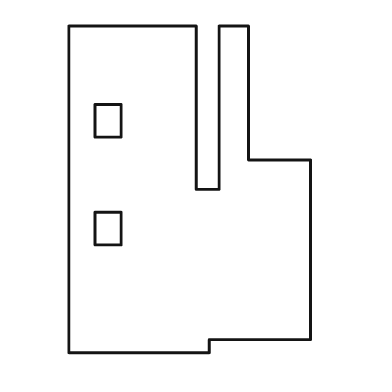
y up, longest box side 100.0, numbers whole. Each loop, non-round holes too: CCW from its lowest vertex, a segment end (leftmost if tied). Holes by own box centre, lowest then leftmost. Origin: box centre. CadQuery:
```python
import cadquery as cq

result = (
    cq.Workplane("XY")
    .moveTo(-37.0, -50.0)
    .lineTo(6.0, -50.0)
    .lineTo(6.0, -46.0)
    .lineTo(37.0, -46.0)
    .lineTo(37.0, 9.0)
    .lineTo(18.0, 9.0)
    .lineTo(18.0, 50.0)
    .lineTo(9.0, 50.0)
    .lineTo(9.0, 0.0)
    .lineTo(2.0, 0.0)
    .lineTo(2.0, 50.0)
    .lineTo(-37.0, 50.0)
    .close()
    .moveTo(-29.0, -17.0)
    .lineTo(-21.0, -17.0)
    .lineTo(-21.0, -7.0)
    .lineTo(-29.0, -7.0)
    .close()
    .moveTo(-29.0, 16.0)
    .lineTo(-21.0, 16.0)
    .lineTo(-21.0, 26.0)
    .lineTo(-29.0, 26.0)
    .close()
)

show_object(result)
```